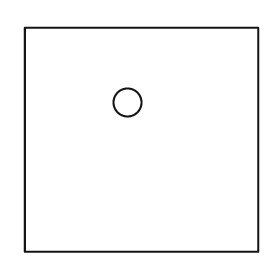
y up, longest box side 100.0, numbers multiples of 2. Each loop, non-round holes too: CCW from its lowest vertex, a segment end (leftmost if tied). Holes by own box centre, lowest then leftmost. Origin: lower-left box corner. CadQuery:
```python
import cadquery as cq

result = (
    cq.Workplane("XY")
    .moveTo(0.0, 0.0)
    .lineTo(100.0, 0.0)
    .lineTo(100.0, 96.0)
    .lineTo(0.0, 96.0)
    .close()
    .moveTo(44.0, 64.0)
    .circle(6.0)
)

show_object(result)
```